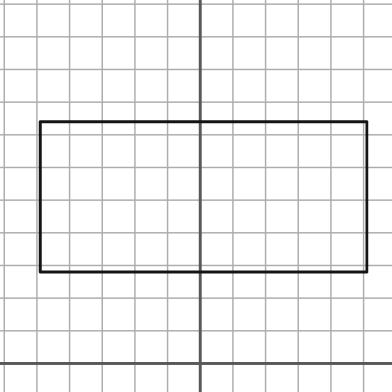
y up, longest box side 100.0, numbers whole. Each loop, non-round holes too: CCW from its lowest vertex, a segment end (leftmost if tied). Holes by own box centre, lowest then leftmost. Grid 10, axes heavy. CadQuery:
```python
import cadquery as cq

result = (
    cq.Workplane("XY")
    .moveTo(-49.0, 28.0)
    .lineTo(51.0, 28.0)
    .lineTo(51.0, 74.0)
    .lineTo(-49.0, 74.0)
    .close()
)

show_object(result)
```